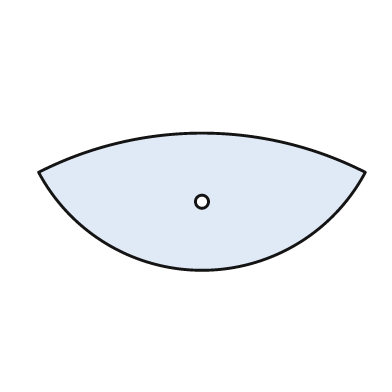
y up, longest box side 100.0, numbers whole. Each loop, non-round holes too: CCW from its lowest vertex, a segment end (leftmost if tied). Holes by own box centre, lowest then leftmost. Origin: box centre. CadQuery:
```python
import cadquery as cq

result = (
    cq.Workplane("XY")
    .moveTo(-50.0, 9.0)
    .threePointArc((0.0, -21.0), (50.0, 9.0))
    .threePointArc((0.0, 21.0), (-50.0, 9.0))
    .close()
    .moveTo(0.0, 0.0)
    .circle(2.0)
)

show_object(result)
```